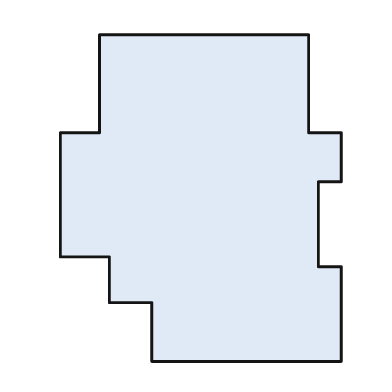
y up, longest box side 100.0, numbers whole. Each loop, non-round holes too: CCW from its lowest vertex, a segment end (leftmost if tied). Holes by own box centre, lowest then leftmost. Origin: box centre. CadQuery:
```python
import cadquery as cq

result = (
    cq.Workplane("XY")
    .moveTo(-15.0, -50.0)
    .lineTo(43.0, -50.0)
    .lineTo(43.0, -21.0)
    .lineTo(36.0, -21.0)
    .lineTo(36.0, 5.0)
    .lineTo(43.0, 5.0)
    .lineTo(43.0, 20.0)
    .lineTo(33.0, 20.0)
    .lineTo(33.0, 50.0)
    .lineTo(-31.0, 50.0)
    .lineTo(-31.0, 20.0)
    .lineTo(-43.0, 20.0)
    .lineTo(-43.0, -18.0)
    .lineTo(-28.0, -18.0)
    .lineTo(-28.0, -32.0)
    .lineTo(-15.0, -32.0)
    .close()
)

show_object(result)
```